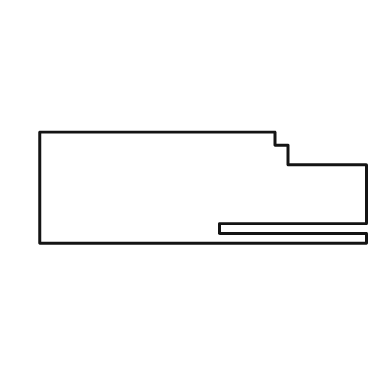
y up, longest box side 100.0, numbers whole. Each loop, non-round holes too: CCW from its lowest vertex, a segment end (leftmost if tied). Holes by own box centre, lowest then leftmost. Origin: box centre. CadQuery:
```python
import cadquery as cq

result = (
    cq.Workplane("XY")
    .moveTo(-50.0, -17.0)
    .lineTo(50.0, -17.0)
    .lineTo(50.0, -14.0)
    .lineTo(5.0, -14.0)
    .lineTo(5.0, -11.0)
    .lineTo(50.0, -11.0)
    .lineTo(50.0, 7.0)
    .lineTo(26.0, 7.0)
    .lineTo(26.0, 13.0)
    .lineTo(22.0, 13.0)
    .lineTo(22.0, 17.0)
    .lineTo(-50.0, 17.0)
    .close()
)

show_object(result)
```